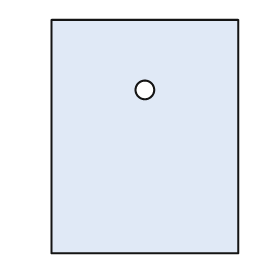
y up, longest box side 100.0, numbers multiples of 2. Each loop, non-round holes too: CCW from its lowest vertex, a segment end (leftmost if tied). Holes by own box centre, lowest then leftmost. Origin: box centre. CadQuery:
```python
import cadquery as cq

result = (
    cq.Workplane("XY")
    .moveTo(-40.0, -50.0)
    .lineTo(40.0, -50.0)
    .lineTo(40.0, 50.0)
    .lineTo(-40.0, 50.0)
    .close()
    .moveTo(0.0, 20.0)
    .circle(4.0)
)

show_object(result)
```